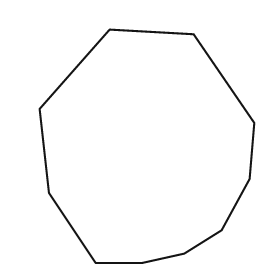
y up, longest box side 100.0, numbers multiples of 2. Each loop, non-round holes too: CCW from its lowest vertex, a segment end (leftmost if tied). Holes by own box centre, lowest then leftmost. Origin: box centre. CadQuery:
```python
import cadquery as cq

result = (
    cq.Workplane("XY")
    .moveTo(-22.0, -50.0)
    .lineTo(-2.0, -50.0)
    .lineTo(16.0, -46.0)
    .lineTo(32.0, -36.0)
    .lineTo(44.0, -14.0)
    .lineTo(46.0, 10.0)
    .lineTo(20.0, 48.0)
    .lineTo(-16.0, 50.0)
    .lineTo(-46.0, 16.0)
    .lineTo(-42.0, -20.0)
    .close()
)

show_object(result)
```